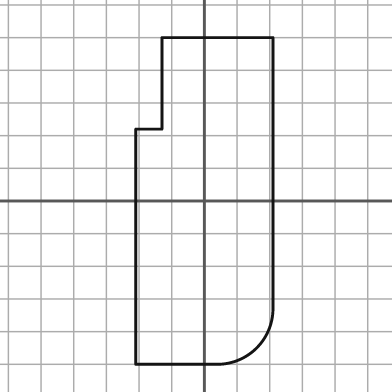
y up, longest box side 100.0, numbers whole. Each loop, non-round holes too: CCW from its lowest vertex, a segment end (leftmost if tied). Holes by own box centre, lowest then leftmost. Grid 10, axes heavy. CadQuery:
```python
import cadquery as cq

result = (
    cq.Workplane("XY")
    .moveTo(-21.0, -50.0)
    .lineTo(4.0, -50.0)
    .threePointArc((16.0, -45.0), (21.0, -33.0))
    .lineTo(21.0, 50.0)
    .lineTo(-13.0, 50.0)
    .lineTo(-13.0, 22.0)
    .lineTo(-21.0, 22.0)
    .close()
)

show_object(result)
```